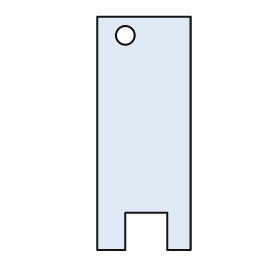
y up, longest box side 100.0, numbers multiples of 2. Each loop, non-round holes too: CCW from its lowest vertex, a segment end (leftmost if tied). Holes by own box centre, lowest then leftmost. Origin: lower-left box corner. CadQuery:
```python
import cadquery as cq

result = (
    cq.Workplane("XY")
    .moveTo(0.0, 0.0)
    .lineTo(12.0, 0.0)
    .lineTo(12.0, 16.0)
    .lineTo(30.0, 16.0)
    .lineTo(30.0, 0.0)
    .lineTo(40.0, 0.0)
    .lineTo(40.0, 100.0)
    .lineTo(0.0, 100.0)
    .close()
    .moveTo(12.0, 92.0)
    .circle(4.0)
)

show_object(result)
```